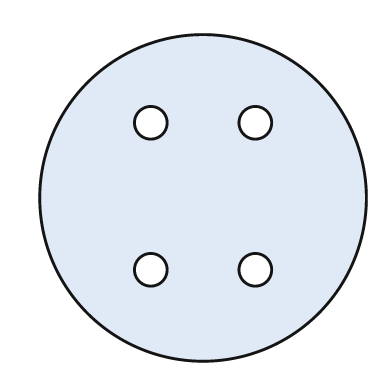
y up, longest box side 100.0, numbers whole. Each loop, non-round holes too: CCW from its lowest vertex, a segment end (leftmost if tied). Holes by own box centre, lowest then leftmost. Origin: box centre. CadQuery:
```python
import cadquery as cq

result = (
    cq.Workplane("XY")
    .moveTo(0.0, 0.0)
    .circle(50.0)
    .moveTo(-16.0, -22.0)
    .circle(5.0)
    .moveTo(16.0, -22.0)
    .circle(5.0)
    .moveTo(-16.0, 23.0)
    .circle(5.0)
    .moveTo(16.0, 23.0)
    .circle(5.0)
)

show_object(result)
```